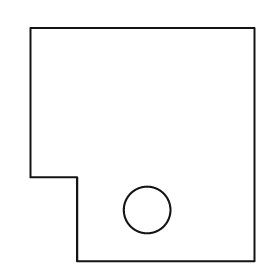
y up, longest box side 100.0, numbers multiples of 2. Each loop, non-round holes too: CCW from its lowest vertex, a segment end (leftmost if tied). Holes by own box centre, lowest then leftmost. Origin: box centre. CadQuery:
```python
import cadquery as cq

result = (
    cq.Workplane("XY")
    .moveTo(-28.0, -50.0)
    .lineTo(48.0, -50.0)
    .lineTo(48.0, 50.0)
    .lineTo(-48.0, 50.0)
    .lineTo(-48.0, -14.0)
    .lineTo(-28.0, -14.0)
    .close()
    .moveTo(2.0, -28.0)
    .circle(10.0)
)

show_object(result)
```